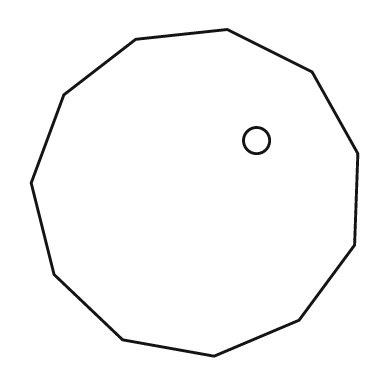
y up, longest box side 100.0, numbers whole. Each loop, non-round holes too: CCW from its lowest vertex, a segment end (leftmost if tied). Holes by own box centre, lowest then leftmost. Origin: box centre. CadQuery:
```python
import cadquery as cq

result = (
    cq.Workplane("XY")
    .moveTo(6.0, -50.0)
    .lineTo(32.0, -39.0)
    .lineTo(49.0, -16.0)
    .lineTo(50.0, 12.0)
    .lineTo(36.0, 37.0)
    .lineTo(10.0, 50.0)
    .lineTo(-18.0, 47.0)
    .lineTo(-40.0, 30.0)
    .lineTo(-50.0, 3.0)
    .lineTo(-43.0, -25.0)
    .lineTo(-22.0, -45.0)
    .close()
    .moveTo(19.0, 16.0)
    .circle(4.0)
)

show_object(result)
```